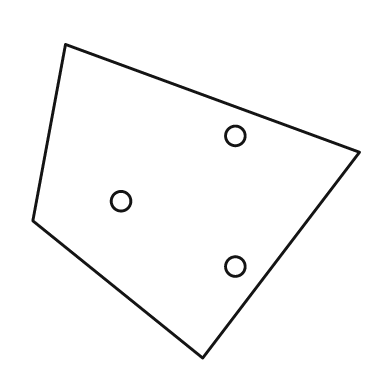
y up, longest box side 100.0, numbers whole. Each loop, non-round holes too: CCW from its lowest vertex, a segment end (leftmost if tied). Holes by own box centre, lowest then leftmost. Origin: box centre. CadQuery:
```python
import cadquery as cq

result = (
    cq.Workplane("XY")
    .moveTo(2.0, -48.0)
    .lineTo(50.0, 15.0)
    .lineTo(-40.0, 48.0)
    .lineTo(-50.0, -6.0)
    .close()
    .moveTo(12.0, -20.0)
    .circle(3.0)
    .moveTo(-23.0, 0.0)
    .circle(3.0)
    .moveTo(12.0, 20.0)
    .circle(3.0)
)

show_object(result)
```